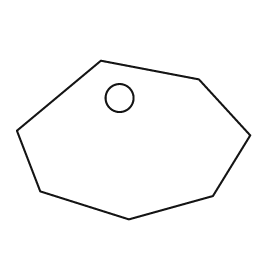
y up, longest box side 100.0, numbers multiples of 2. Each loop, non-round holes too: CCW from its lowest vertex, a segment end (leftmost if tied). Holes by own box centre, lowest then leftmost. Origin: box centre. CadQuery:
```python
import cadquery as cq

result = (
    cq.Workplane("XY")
    .moveTo(-2.0, -34.0)
    .lineTo(34.0, -24.0)
    .lineTo(50.0, 2.0)
    .lineTo(28.0, 26.0)
    .lineTo(-14.0, 34.0)
    .lineTo(-50.0, 4.0)
    .lineTo(-40.0, -22.0)
    .close()
    .moveTo(-6.0, 18.0)
    .circle(6.0)
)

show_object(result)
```